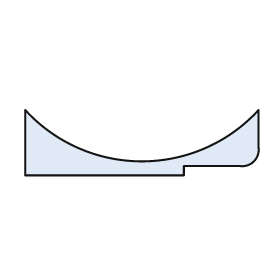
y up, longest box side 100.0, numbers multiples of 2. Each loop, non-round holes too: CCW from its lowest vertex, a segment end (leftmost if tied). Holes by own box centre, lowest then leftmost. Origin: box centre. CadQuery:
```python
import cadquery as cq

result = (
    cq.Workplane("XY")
    .moveTo(-50.0, -14.0)
    .lineTo(18.0, -14.0)
    .lineTo(18.0, -10.0)
    .lineTo(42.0, -10.0)
    .threePointArc((48.0, -8.0), (50.0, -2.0))
    .lineTo(50.0, 14.0)
    .threePointArc((0.0, -8.0), (-50.0, 14.0))
    .close()
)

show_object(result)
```